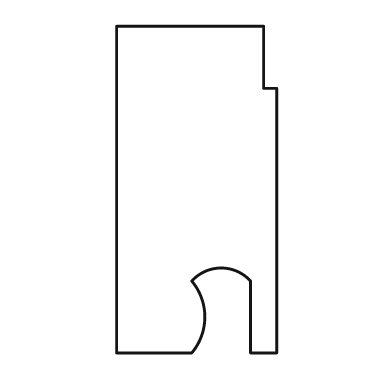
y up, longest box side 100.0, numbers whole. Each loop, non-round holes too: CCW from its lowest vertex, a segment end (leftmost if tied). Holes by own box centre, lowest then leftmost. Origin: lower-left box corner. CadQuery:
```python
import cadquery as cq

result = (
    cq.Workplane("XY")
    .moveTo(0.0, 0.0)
    .lineTo(23.0, 0.0)
    .threePointArc((27.0, 11.0), (23.0, 22.0))
    .threePointArc((32.0, 26.0), (41.0, 22.0))
    .lineTo(41.0, 0.0)
    .lineTo(49.0, 0.0)
    .lineTo(49.0, 81.0)
    .lineTo(45.0, 81.0)
    .lineTo(45.0, 100.0)
    .lineTo(0.0, 100.0)
    .close()
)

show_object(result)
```